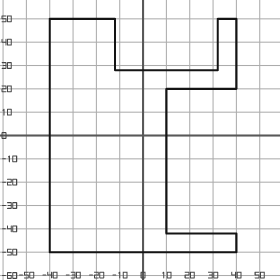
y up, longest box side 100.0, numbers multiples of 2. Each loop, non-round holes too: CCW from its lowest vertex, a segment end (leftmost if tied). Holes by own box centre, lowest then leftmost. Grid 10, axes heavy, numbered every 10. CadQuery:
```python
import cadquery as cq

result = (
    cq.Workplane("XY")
    .moveTo(-40.0, -50.0)
    .lineTo(40.0, -50.0)
    .lineTo(40.0, -42.0)
    .lineTo(10.0, -42.0)
    .lineTo(10.0, 20.0)
    .lineTo(40.0, 20.0)
    .lineTo(40.0, 50.0)
    .lineTo(32.0, 50.0)
    .lineTo(32.0, 28.0)
    .lineTo(-12.0, 28.0)
    .lineTo(-12.0, 50.0)
    .lineTo(-40.0, 50.0)
    .close()
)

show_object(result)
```